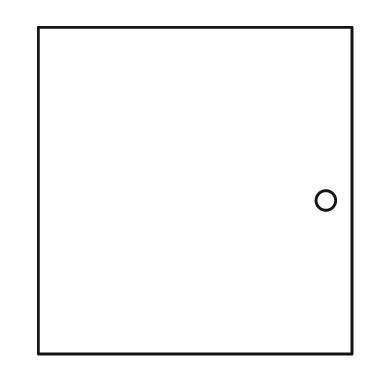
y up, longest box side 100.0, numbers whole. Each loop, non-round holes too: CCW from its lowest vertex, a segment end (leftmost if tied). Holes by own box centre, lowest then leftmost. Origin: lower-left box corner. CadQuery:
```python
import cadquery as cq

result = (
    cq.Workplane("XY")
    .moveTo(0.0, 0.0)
    .lineTo(96.0, 0.0)
    .lineTo(96.0, 100.0)
    .lineTo(0.0, 100.0)
    .close()
    .moveTo(88.0, 47.0)
    .circle(3.0)
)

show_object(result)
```